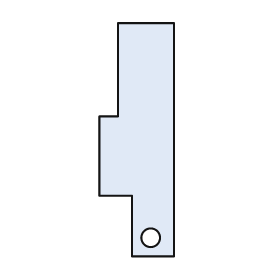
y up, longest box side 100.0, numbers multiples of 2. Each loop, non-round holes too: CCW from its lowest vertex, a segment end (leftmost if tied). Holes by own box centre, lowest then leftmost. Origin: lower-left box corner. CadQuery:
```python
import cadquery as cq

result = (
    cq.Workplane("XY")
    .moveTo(14.0, 0.0)
    .lineTo(32.0, 0.0)
    .lineTo(32.0, 100.0)
    .lineTo(8.0, 100.0)
    .lineTo(8.0, 60.0)
    .lineTo(0.0, 60.0)
    .lineTo(0.0, 26.0)
    .lineTo(14.0, 26.0)
    .close()
    .moveTo(22.0, 8.0)
    .circle(4.0)
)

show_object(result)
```